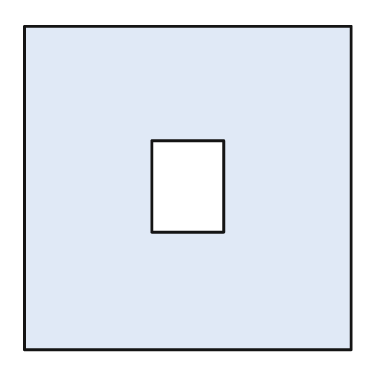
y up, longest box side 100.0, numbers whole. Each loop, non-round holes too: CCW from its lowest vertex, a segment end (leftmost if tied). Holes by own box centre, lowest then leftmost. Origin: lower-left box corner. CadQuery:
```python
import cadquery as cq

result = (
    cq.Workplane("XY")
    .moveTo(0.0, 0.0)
    .lineTo(100.0, 0.0)
    .lineTo(100.0, 99.0)
    .lineTo(0.0, 99.0)
    .close()
    .moveTo(39.0, 36.0)
    .lineTo(61.0, 36.0)
    .lineTo(61.0, 64.0)
    .lineTo(39.0, 64.0)
    .close()
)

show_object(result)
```